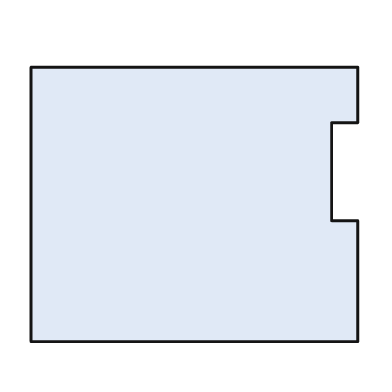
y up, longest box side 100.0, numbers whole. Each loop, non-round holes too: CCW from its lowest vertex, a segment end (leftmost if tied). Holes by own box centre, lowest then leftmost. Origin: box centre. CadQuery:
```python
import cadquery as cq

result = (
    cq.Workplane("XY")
    .moveTo(-50.0, -42.0)
    .lineTo(50.0, -42.0)
    .lineTo(50.0, -5.0)
    .lineTo(42.0, -5.0)
    .lineTo(42.0, 25.0)
    .lineTo(50.0, 25.0)
    .lineTo(50.0, 42.0)
    .lineTo(-50.0, 42.0)
    .close()
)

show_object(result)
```